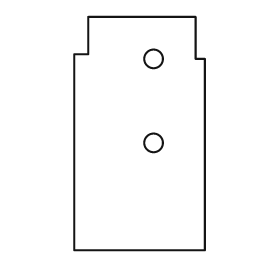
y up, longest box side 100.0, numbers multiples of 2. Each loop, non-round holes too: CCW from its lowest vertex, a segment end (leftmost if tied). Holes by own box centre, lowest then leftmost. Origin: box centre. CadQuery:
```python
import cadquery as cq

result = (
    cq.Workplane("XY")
    .moveTo(-28.0, -50.0)
    .lineTo(28.0, -50.0)
    .lineTo(28.0, 32.0)
    .lineTo(24.0, 32.0)
    .lineTo(24.0, 50.0)
    .lineTo(-22.0, 50.0)
    .lineTo(-22.0, 34.0)
    .lineTo(-28.0, 34.0)
    .close()
    .moveTo(6.0, -4.0)
    .circle(4.0)
    .moveTo(6.0, 32.0)
    .circle(4.0)
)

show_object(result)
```